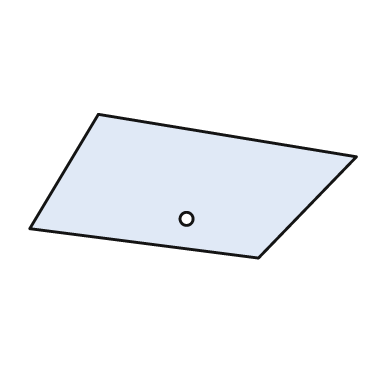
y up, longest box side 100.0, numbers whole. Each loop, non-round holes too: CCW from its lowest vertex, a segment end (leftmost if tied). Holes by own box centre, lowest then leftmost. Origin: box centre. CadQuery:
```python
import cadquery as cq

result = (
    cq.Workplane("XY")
    .moveTo(20.0, -22.0)
    .lineTo(50.0, 9.0)
    .lineTo(-29.0, 22.0)
    .lineTo(-50.0, -13.0)
    .close()
    .moveTo(-2.0, -10.0)
    .circle(2.0)
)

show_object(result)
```